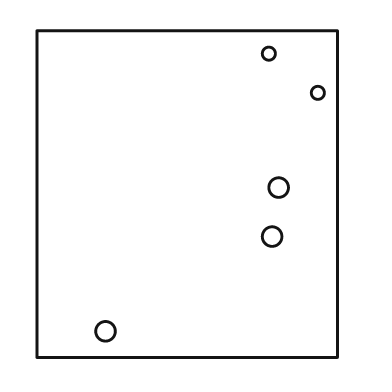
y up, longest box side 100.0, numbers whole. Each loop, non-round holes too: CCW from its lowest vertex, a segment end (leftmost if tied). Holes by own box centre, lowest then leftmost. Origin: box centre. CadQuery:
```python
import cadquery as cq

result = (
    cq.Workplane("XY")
    .moveTo(-46.0, -50.0)
    .lineTo(46.0, -50.0)
    .lineTo(46.0, 50.0)
    .lineTo(-46.0, 50.0)
    .close()
    .moveTo(-25.0, -42.0)
    .circle(3.0)
    .moveTo(26.0, -13.0)
    .circle(3.0)
    .moveTo(28.0, 2.0)
    .circle(3.0)
    .moveTo(40.0, 31.0)
    .circle(2.0)
    .moveTo(25.0, 43.0)
    .circle(2.0)
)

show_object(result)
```